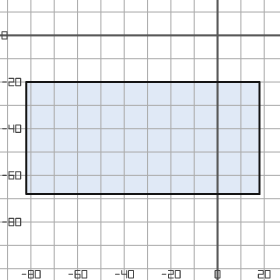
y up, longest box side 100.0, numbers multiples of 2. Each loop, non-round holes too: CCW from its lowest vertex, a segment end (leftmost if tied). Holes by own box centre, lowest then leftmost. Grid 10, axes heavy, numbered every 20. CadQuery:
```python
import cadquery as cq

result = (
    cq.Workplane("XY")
    .moveTo(-82.0, -68.0)
    .lineTo(18.0, -68.0)
    .lineTo(18.0, -20.0)
    .lineTo(-82.0, -20.0)
    .close()
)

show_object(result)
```